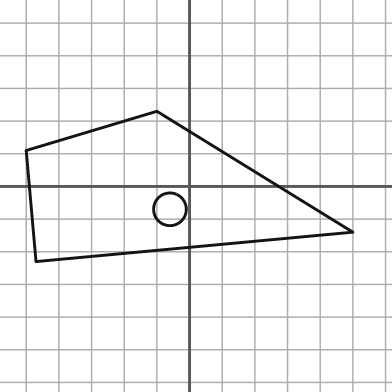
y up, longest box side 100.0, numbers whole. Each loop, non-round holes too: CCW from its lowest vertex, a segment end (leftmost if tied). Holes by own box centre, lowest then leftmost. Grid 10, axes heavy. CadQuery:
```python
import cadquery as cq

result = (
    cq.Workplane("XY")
    .moveTo(-47.0, -23.0)
    .lineTo(50.0, -14.0)
    .lineTo(-10.0, 23.0)
    .lineTo(-50.0, 11.0)
    .close()
    .moveTo(-6.0, -7.0)
    .circle(5.0)
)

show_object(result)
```